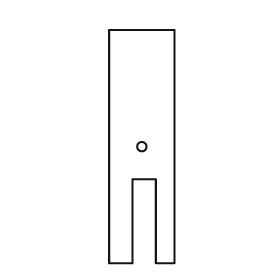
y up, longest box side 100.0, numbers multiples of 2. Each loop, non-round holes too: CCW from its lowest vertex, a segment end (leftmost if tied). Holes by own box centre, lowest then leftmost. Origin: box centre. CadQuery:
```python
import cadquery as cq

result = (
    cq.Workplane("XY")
    .moveTo(-14.0, -50.0)
    .lineTo(-4.0, -50.0)
    .lineTo(-4.0, -14.0)
    .lineTo(6.0, -14.0)
    .lineTo(6.0, -50.0)
    .lineTo(14.0, -50.0)
    .lineTo(14.0, 50.0)
    .lineTo(-14.0, 50.0)
    .close()
    .moveTo(0.0, 0.0)
    .circle(2.0)
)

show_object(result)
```